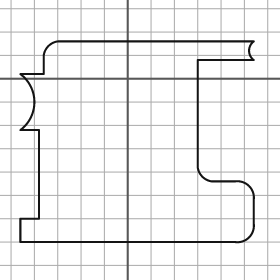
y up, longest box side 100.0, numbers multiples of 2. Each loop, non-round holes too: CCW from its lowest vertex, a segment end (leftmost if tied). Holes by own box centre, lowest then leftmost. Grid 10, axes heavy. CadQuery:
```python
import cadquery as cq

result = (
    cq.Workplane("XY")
    .moveTo(-46.0, -70.0)
    .lineTo(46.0, -70.0)
    .threePointArc((52.0, -68.0), (54.0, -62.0))
    .lineTo(54.0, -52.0)
    .threePointArc((52.0, -46.0), (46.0, -44.0))
    .lineTo(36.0, -44.0)
    .threePointArc((32.0, -42.0), (30.0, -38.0))
    .lineTo(30.0, 8.0)
    .lineTo(54.0, 8.0)
    .threePointArc((52.0, 12.0), (54.0, 16.0))
    .lineTo(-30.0, 16.0)
    .threePointArc((-34.0, 14.0), (-36.0, 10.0))
    .lineTo(-36.0, 2.0)
    .lineTo(-46.0, 2.0)
    .threePointArc((-40.0, -10.0), (-46.0, -22.0))
    .lineTo(-38.0, -22.0)
    .lineTo(-38.0, -60.0)
    .lineTo(-46.0, -60.0)
    .close()
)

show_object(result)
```